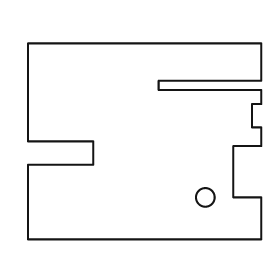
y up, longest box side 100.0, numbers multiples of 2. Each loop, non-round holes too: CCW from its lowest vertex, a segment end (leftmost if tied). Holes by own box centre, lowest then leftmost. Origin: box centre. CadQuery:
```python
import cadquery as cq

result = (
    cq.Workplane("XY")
    .moveTo(-50.0, -42.0)
    .lineTo(50.0, -42.0)
    .lineTo(50.0, -24.0)
    .lineTo(38.0, -24.0)
    .lineTo(38.0, -2.0)
    .lineTo(50.0, -2.0)
    .lineTo(50.0, 6.0)
    .lineTo(46.0, 6.0)
    .lineTo(46.0, 16.0)
    .lineTo(50.0, 16.0)
    .lineTo(50.0, 22.0)
    .lineTo(6.0, 22.0)
    .lineTo(6.0, 26.0)
    .lineTo(50.0, 26.0)
    .lineTo(50.0, 42.0)
    .lineTo(-50.0, 42.0)
    .lineTo(-50.0, 0.0)
    .lineTo(-22.0, 0.0)
    .lineTo(-22.0, -10.0)
    .lineTo(-50.0, -10.0)
    .close()
    .moveTo(26.0, -24.0)
    .circle(4.0)
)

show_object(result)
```